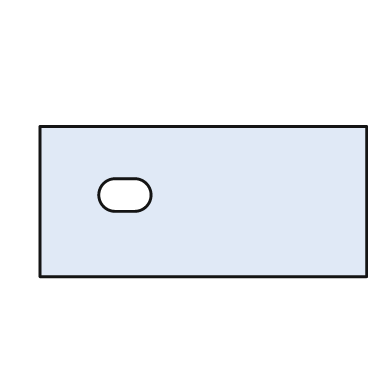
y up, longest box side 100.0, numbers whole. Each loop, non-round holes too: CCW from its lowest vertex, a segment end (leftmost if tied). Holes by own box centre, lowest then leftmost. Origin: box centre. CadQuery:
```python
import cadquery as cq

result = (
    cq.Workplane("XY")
    .moveTo(-50.0, -23.0)
    .lineTo(50.0, -23.0)
    .lineTo(50.0, 23.0)
    .lineTo(-50.0, 23.0)
    .close()
    .moveTo(-27.0, -3.0)
    .lineTo(-21.0, -3.0)
    .threePointArc((-16.0, 2.0), (-21.0, 7.0))
    .lineTo(-27.0, 7.0)
    .threePointArc((-32.0, 2.0), (-27.0, -3.0))
    .close()
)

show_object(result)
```